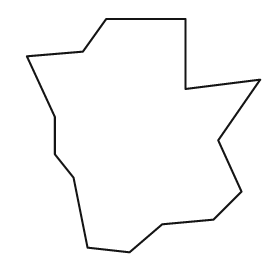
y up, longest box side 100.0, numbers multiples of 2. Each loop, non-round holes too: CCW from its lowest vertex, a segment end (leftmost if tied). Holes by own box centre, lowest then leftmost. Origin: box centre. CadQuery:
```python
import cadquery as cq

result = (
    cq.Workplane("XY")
    .moveTo(-6.0, -50.0)
    .lineTo(8.0, -38.0)
    .lineTo(30.0, -36.0)
    .lineTo(42.0, -24.0)
    .lineTo(32.0, -2.0)
    .lineTo(50.0, 24.0)
    .lineTo(18.0, 20.0)
    .lineTo(18.0, 50.0)
    .lineTo(-16.0, 50.0)
    .lineTo(-26.0, 36.0)
    .lineTo(-50.0, 34.0)
    .lineTo(-38.0, 8.0)
    .lineTo(-38.0, -8.0)
    .lineTo(-30.0, -18.0)
    .lineTo(-24.0, -48.0)
    .close()
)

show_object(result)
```